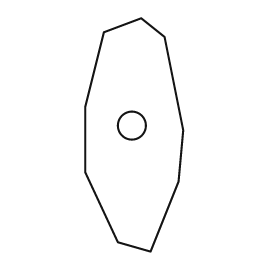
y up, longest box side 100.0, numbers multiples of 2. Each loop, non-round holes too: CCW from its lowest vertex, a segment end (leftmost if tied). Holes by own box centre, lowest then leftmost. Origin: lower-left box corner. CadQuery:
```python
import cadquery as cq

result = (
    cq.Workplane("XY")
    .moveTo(28.0, 0.0)
    .lineTo(40.0, 30.0)
    .lineTo(42.0, 52.0)
    .lineTo(34.0, 92.0)
    .lineTo(24.0, 100.0)
    .lineTo(8.0, 94.0)
    .lineTo(0.0, 62.0)
    .lineTo(0.0, 34.0)
    .lineTo(14.0, 4.0)
    .close()
    .moveTo(20.0, 54.0)
    .circle(6.0)
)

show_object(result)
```